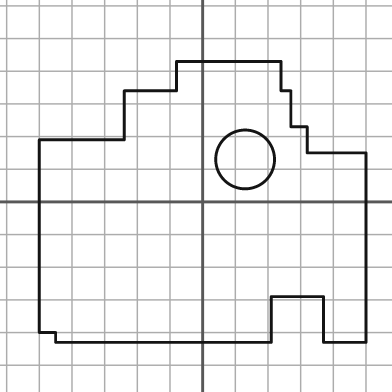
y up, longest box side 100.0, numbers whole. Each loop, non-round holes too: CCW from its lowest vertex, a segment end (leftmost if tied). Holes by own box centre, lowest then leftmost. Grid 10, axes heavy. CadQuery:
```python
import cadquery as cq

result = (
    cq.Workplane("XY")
    .moveTo(-45.0, -43.0)
    .lineTo(21.0, -43.0)
    .lineTo(21.0, -29.0)
    .lineTo(37.0, -29.0)
    .lineTo(37.0, -43.0)
    .lineTo(50.0, -43.0)
    .lineTo(50.0, 15.0)
    .lineTo(32.0, 15.0)
    .lineTo(32.0, 23.0)
    .lineTo(27.0, 23.0)
    .lineTo(27.0, 34.0)
    .lineTo(24.0, 34.0)
    .lineTo(24.0, 43.0)
    .lineTo(-8.0, 43.0)
    .lineTo(-8.0, 34.0)
    .lineTo(-24.0, 34.0)
    .lineTo(-24.0, 19.0)
    .lineTo(-50.0, 19.0)
    .lineTo(-50.0, -40.0)
    .lineTo(-45.0, -40.0)
    .close()
    .moveTo(13.0, 13.0)
    .circle(9.0)
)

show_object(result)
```